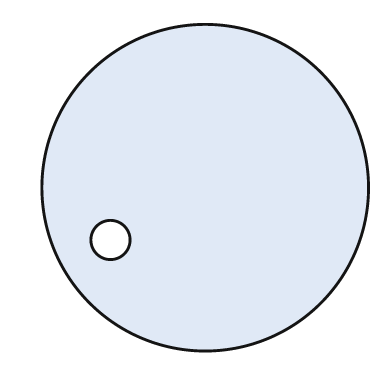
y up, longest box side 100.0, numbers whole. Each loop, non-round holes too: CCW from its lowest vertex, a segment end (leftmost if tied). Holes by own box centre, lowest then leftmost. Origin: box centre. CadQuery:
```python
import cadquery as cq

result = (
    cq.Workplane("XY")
    .moveTo(0.0, 0.0)
    .circle(50.0)
    .moveTo(-29.0, -16.0)
    .circle(6.0)
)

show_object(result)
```